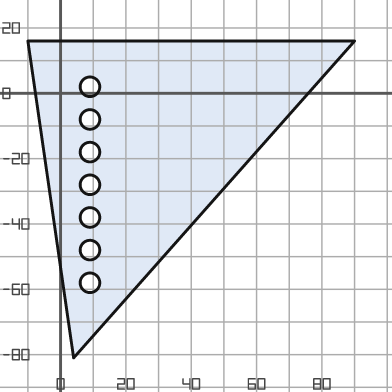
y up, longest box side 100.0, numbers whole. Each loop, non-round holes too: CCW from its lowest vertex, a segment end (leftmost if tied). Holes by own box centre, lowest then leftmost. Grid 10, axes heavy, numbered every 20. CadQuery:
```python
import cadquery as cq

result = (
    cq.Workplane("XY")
    .moveTo(4.0, -81.0)
    .lineTo(90.0, 16.0)
    .lineTo(-10.0, 16.0)
    .close()
    .moveTo(9.0, -58.0)
    .circle(3.0)
    .moveTo(9.0, -48.0)
    .circle(3.0)
    .moveTo(9.0, -38.0)
    .circle(3.0)
    .moveTo(9.0, -28.0)
    .circle(3.0)
    .moveTo(9.0, -18.0)
    .circle(3.0)
    .moveTo(9.0, -8.0)
    .circle(3.0)
    .moveTo(9.0, 2.0)
    .circle(3.0)
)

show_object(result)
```